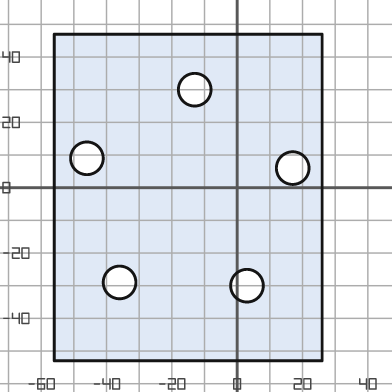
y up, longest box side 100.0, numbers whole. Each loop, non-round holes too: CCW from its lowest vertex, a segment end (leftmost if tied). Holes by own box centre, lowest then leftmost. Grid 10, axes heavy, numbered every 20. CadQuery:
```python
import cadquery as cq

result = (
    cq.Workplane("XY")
    .moveTo(-56.0, -53.0)
    .lineTo(26.0, -53.0)
    .lineTo(26.0, 47.0)
    .lineTo(-56.0, 47.0)
    .close()
    .moveTo(3.0, -30.0)
    .circle(5.0)
    .moveTo(-36.0, -29.0)
    .circle(5.0)
    .moveTo(17.0, 6.0)
    .circle(5.0)
    .moveTo(-46.0, 9.0)
    .circle(5.0)
    .moveTo(-13.0, 30.0)
    .circle(5.0)
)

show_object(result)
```